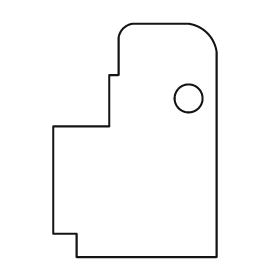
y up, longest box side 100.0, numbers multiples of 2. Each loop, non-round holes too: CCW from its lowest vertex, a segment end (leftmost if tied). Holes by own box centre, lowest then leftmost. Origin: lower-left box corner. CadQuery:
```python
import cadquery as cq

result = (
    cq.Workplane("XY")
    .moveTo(10.0, 0.0)
    .lineTo(70.0, 0.0)
    .lineTo(70.0, 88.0)
    .threePointArc((66.0, 96.0), (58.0, 100.0))
    .lineTo(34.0, 100.0)
    .threePointArc((30.0, 98.0), (28.0, 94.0))
    .lineTo(28.0, 78.0)
    .lineTo(24.0, 78.0)
    .lineTo(24.0, 56.0)
    .lineTo(0.0, 56.0)
    .lineTo(0.0, 10.0)
    .lineTo(10.0, 10.0)
    .close()
    .moveTo(58.0, 68.0)
    .circle(6.0)
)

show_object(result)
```